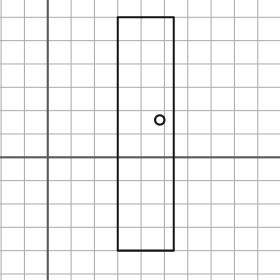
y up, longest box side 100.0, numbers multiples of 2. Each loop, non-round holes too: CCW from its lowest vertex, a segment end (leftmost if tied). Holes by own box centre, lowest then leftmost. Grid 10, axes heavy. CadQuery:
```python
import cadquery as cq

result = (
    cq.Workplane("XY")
    .moveTo(30.0, -40.0)
    .lineTo(54.0, -40.0)
    .lineTo(54.0, 60.0)
    .lineTo(30.0, 60.0)
    .close()
    .moveTo(48.0, 16.0)
    .circle(2.0)
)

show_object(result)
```